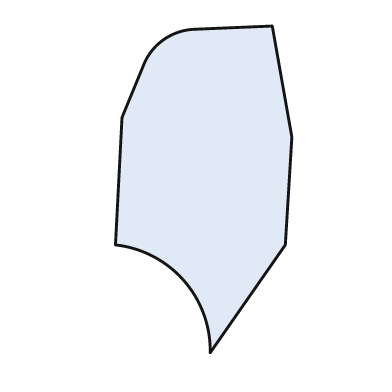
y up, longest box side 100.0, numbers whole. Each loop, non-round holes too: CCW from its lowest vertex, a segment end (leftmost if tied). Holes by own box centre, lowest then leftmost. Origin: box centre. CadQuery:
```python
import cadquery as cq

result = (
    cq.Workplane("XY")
    .moveTo(2.0, -50.0)
    .lineTo(25.0, -17.0)
    .lineTo(27.0, 16.0)
    .lineTo(21.0, 50.0)
    .lineTo(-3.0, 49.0)
    .threePointArc((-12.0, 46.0), (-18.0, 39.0))
    .lineTo(-25.0, 22.0)
    .lineTo(-27.0, -17.0)
    .threePointArc((-6.0, -28.0), (2.0, -50.0))
    .close()
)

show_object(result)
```